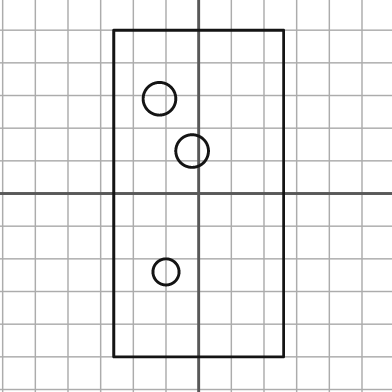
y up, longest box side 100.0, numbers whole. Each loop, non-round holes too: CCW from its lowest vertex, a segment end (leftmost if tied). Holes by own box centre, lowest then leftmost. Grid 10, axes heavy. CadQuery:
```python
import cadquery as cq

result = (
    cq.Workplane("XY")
    .moveTo(-26.0, -50.0)
    .lineTo(26.0, -50.0)
    .lineTo(26.0, 50.0)
    .lineTo(-26.0, 50.0)
    .close()
    .moveTo(-10.0, -24.0)
    .circle(4.0)
    .moveTo(-2.0, 13.0)
    .circle(5.0)
    .moveTo(-12.0, 29.0)
    .circle(5.0)
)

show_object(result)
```